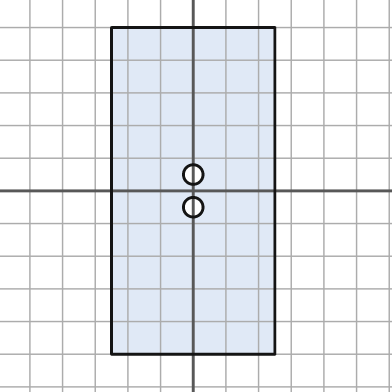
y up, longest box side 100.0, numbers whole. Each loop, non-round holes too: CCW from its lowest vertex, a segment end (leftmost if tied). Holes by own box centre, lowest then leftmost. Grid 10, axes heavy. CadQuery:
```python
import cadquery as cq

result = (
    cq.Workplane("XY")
    .moveTo(-25.0, -50.0)
    .lineTo(25.0, -50.0)
    .lineTo(25.0, 50.0)
    .lineTo(-25.0, 50.0)
    .close()
    .moveTo(0.0, -5.0)
    .circle(3.0)
    .moveTo(0.0, 5.0)
    .circle(3.0)
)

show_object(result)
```